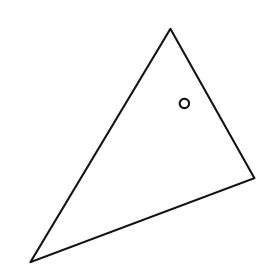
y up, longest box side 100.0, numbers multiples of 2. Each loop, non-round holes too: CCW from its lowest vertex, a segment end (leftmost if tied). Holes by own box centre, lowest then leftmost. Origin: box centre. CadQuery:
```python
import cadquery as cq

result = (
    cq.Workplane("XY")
    .moveTo(-48.0, -50.0)
    .lineTo(48.0, -14.0)
    .lineTo(12.0, 50.0)
    .close()
    .moveTo(18.0, 18.0)
    .circle(2.0)
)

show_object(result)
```